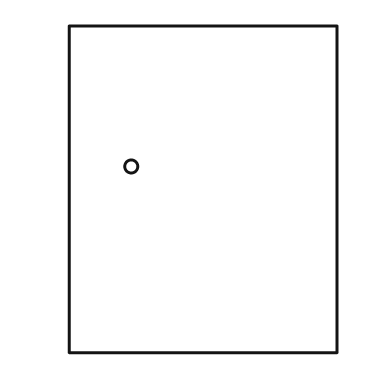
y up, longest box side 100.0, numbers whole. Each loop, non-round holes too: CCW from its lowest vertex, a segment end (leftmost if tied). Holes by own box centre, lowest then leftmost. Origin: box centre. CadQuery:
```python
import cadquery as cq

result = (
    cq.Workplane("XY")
    .moveTo(-41.0, -50.0)
    .lineTo(41.0, -50.0)
    .lineTo(41.0, 50.0)
    .lineTo(-41.0, 50.0)
    .close()
    .moveTo(-22.0, 7.0)
    .circle(2.0)
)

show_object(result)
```